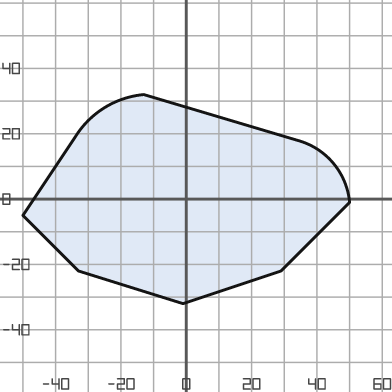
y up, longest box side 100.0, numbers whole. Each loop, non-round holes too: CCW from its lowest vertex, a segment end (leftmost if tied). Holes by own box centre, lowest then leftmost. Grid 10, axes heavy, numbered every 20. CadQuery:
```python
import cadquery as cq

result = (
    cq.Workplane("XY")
    .moveTo(-1.0, -32.0)
    .lineTo(29.0, -22.0)
    .lineTo(50.0, -1.0)
    .threePointArc((45.0, 11.0), (34.0, 18.0))
    .lineTo(-13.0, 32.0)
    .threePointArc((-25.0, 28.0), (-34.0, 19.0))
    .lineTo(-50.0, -5.0)
    .lineTo(-33.0, -22.0)
    .close()
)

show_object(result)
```